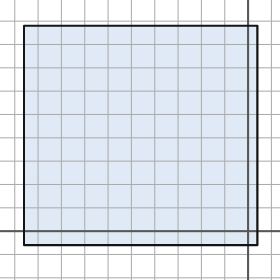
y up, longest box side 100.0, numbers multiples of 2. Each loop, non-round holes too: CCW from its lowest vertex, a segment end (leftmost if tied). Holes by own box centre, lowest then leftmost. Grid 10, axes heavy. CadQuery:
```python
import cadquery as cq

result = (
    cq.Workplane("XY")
    .moveTo(-96.0, -6.0)
    .lineTo(4.0, -6.0)
    .lineTo(4.0, 88.0)
    .lineTo(-96.0, 88.0)
    .close()
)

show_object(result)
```